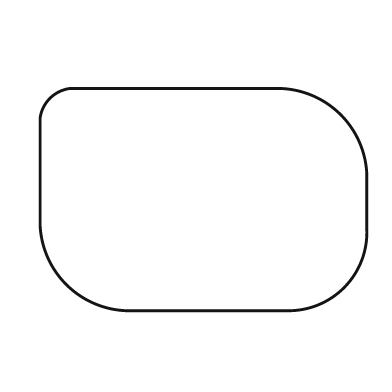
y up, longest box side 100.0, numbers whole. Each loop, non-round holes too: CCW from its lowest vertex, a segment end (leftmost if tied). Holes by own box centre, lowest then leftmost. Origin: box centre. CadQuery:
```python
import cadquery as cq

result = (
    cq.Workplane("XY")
    .moveTo(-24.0, -34.0)
    .lineTo(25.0, -34.0)
    .threePointArc((43.0, -27.0), (50.0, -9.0))
    .lineTo(50.0, 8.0)
    .threePointArc((42.0, 26.0), (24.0, 34.0))
    .lineTo(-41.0, 34.0)
    .threePointArc((-47.0, 31.0), (-50.0, 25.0))
    .lineTo(-50.0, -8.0)
    .threePointArc((-42.0, -26.0), (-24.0, -34.0))
    .close()
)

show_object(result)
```